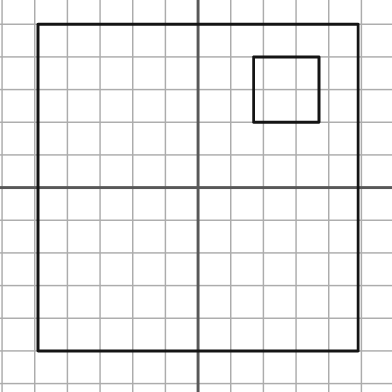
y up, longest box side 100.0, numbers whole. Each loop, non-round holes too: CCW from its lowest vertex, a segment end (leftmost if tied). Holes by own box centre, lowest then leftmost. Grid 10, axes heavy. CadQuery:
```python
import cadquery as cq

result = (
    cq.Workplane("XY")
    .moveTo(-49.0, -50.0)
    .lineTo(49.0, -50.0)
    .lineTo(49.0, 50.0)
    .lineTo(-49.0, 50.0)
    .close()
    .moveTo(17.0, 20.0)
    .lineTo(37.0, 20.0)
    .lineTo(37.0, 40.0)
    .lineTo(17.0, 40.0)
    .close()
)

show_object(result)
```